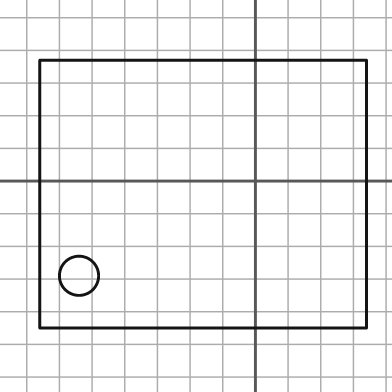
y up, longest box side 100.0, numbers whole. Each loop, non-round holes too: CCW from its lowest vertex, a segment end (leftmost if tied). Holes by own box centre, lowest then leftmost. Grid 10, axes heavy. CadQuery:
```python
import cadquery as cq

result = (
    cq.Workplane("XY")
    .moveTo(-66.0, -45.0)
    .lineTo(34.0, -45.0)
    .lineTo(34.0, 37.0)
    .lineTo(-66.0, 37.0)
    .close()
    .moveTo(-54.0, -29.0)
    .circle(6.0)
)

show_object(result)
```